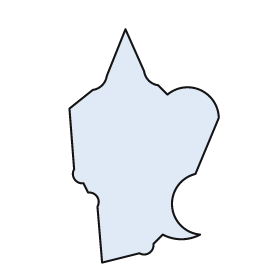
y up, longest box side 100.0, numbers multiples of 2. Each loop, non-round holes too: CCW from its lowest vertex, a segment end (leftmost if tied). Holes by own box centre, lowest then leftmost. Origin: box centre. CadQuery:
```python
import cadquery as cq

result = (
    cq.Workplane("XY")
    .moveTo(-18.0, -50.0)
    .lineTo(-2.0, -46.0)
    .threePointArc((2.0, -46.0), (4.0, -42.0))
    .lineTo(8.0, -38.0)
    .threePointArc((16.0, -40.0), (24.0, -38.0))
    .threePointArc((12.0, -26.0), (22.0, -12.0))
    .lineTo(32.0, 12.0)
    .threePointArc((24.0, 24.0), (10.0, 22.0))
    .lineTo(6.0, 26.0)
    .threePointArc((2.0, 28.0), (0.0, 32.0))
    .lineTo(-8.0, 50.0)
    .lineTo(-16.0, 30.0)
    .threePointArc((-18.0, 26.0), (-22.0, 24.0))
    .lineTo(-32.0, 16.0)
    .lineTo(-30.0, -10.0)
    .threePointArc((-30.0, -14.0), (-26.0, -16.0))
    .lineTo(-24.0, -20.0)
    .threePointArc((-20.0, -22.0), (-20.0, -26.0))
    .close()
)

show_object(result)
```